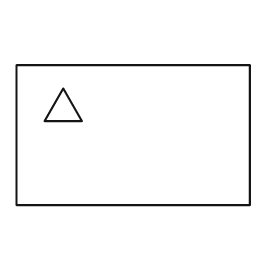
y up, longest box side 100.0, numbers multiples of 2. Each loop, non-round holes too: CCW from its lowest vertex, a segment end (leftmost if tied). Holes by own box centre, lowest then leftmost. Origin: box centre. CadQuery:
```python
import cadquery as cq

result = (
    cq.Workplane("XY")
    .moveTo(-50.0, -30.0)
    .lineTo(50.0, -30.0)
    .lineTo(50.0, 30.0)
    .lineTo(-50.0, 30.0)
    .close()
    .moveTo(-38.0, 6.0)
    .lineTo(-22.0, 6.0)
    .lineTo(-30.0, 20.0)
    .close()
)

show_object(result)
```